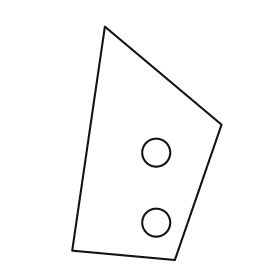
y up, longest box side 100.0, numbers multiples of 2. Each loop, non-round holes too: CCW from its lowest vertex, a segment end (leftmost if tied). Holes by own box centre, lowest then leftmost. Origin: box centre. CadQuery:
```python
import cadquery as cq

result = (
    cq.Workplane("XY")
    .moveTo(12.0, -50.0)
    .lineTo(32.0, 8.0)
    .lineTo(-18.0, 50.0)
    .lineTo(-32.0, -46.0)
    .close()
    .moveTo(4.0, -34.0)
    .circle(6.0)
    .moveTo(4.0, -4.0)
    .circle(6.0)
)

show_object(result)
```